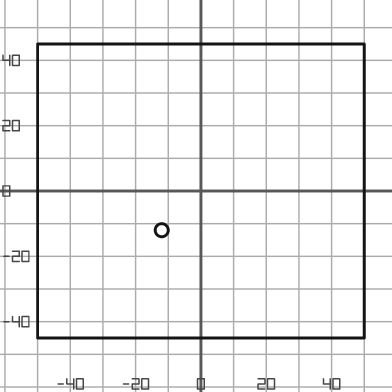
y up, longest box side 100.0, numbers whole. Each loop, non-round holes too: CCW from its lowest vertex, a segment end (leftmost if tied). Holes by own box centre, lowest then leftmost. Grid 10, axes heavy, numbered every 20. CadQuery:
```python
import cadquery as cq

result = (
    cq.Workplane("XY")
    .moveTo(-50.0, -45.0)
    .lineTo(50.0, -45.0)
    .lineTo(50.0, 45.0)
    .lineTo(-50.0, 45.0)
    .close()
    .moveTo(-12.0, -12.0)
    .circle(2.0)
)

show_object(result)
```